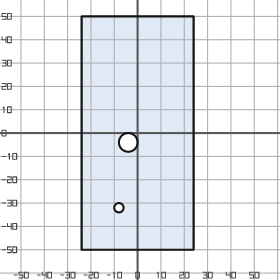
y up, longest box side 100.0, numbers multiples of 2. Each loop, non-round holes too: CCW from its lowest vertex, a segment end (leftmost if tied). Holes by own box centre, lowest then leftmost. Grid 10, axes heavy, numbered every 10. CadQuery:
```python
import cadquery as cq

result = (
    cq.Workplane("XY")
    .moveTo(-24.0, -50.0)
    .lineTo(24.0, -50.0)
    .lineTo(24.0, 50.0)
    .lineTo(-24.0, 50.0)
    .close()
    .moveTo(-8.0, -32.0)
    .circle(2.0)
    .moveTo(-4.0, -4.0)
    .circle(4.0)
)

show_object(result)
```